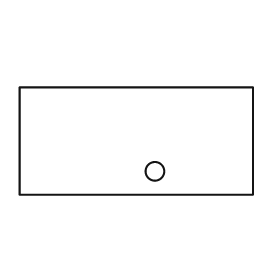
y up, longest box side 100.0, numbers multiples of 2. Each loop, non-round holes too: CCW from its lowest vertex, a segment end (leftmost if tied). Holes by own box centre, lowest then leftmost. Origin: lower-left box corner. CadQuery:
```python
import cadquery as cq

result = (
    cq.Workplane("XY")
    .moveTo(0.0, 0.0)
    .lineTo(100.0, 0.0)
    .lineTo(100.0, 46.0)
    .lineTo(0.0, 46.0)
    .close()
    .moveTo(58.0, 10.0)
    .circle(4.0)
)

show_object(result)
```